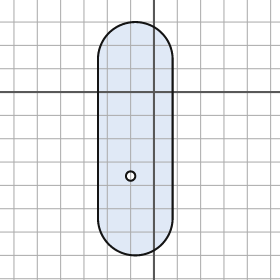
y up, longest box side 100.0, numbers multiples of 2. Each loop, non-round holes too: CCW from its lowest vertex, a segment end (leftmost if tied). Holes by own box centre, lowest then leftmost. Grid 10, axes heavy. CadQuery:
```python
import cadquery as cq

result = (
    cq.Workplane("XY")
    .moveTo(-24.0, -54.0)
    .threePointArc((-8.0, -70.0), (8.0, -54.0))
    .lineTo(8.0, 14.0)
    .threePointArc((-8.0, 30.0), (-24.0, 14.0))
    .close()
    .moveTo(-10.0, -36.0)
    .circle(2.0)
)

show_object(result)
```